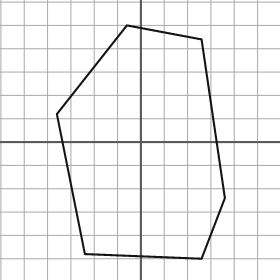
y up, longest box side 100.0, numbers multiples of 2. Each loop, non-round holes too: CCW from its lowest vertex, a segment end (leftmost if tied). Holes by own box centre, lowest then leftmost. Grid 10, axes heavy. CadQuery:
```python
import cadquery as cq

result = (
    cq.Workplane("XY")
    .moveTo(26.0, -50.0)
    .lineTo(36.0, -24.0)
    .lineTo(26.0, 44.0)
    .lineTo(-6.0, 50.0)
    .lineTo(-36.0, 12.0)
    .lineTo(-24.0, -48.0)
    .close()
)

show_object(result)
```